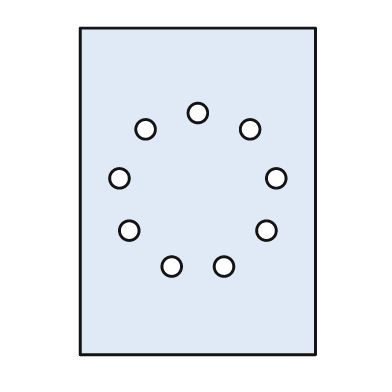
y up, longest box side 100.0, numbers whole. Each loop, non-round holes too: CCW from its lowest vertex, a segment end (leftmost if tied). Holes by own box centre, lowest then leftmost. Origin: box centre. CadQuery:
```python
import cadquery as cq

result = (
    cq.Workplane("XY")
    .moveTo(-36.0, -50.0)
    .lineTo(36.0, -50.0)
    .lineTo(36.0, 50.0)
    .lineTo(-36.0, 50.0)
    .close()
    .moveTo(-8.0, -23.0)
    .circle(3.0)
    .moveTo(8.0, -23.0)
    .circle(3.0)
    .moveTo(-21.0, -12.0)
    .circle(3.0)
    .moveTo(21.0, -12.0)
    .circle(3.0)
    .moveTo(-24.0, 4.0)
    .circle(3.0)
    .moveTo(24.0, 4.0)
    .circle(3.0)
    .moveTo(-16.0, 19.0)
    .circle(3.0)
    .moveTo(16.0, 19.0)
    .circle(3.0)
    .moveTo(0.0, 24.0)
    .circle(3.0)
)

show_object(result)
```